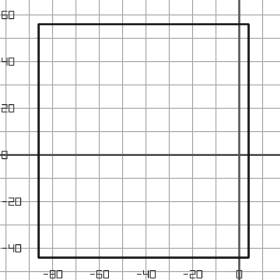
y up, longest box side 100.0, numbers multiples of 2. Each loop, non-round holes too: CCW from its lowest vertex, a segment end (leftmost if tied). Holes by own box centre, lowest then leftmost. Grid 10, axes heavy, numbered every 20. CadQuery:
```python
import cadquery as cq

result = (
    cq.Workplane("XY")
    .moveTo(-86.0, -44.0)
    .lineTo(4.0, -44.0)
    .lineTo(4.0, 56.0)
    .lineTo(-86.0, 56.0)
    .close()
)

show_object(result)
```